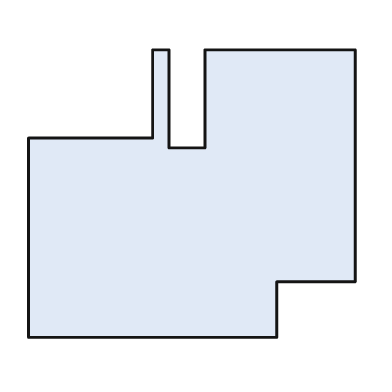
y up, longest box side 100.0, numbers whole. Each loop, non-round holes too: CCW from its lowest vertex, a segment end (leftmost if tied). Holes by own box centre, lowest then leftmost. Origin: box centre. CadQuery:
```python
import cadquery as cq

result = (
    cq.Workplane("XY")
    .moveTo(-50.0, -44.0)
    .lineTo(26.0, -44.0)
    .lineTo(26.0, -27.0)
    .lineTo(50.0, -27.0)
    .lineTo(50.0, 44.0)
    .lineTo(4.0, 44.0)
    .lineTo(4.0, 14.0)
    .lineTo(-7.0, 14.0)
    .lineTo(-7.0, 44.0)
    .lineTo(-12.0, 44.0)
    .lineTo(-12.0, 17.0)
    .lineTo(-50.0, 17.0)
    .close()
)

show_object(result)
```